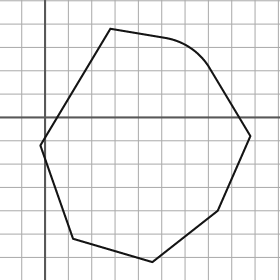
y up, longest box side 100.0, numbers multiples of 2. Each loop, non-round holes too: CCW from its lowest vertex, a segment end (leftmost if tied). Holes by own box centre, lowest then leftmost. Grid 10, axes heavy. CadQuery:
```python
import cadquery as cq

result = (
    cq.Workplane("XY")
    .moveTo(46.0, -62.0)
    .lineTo(74.0, -40.0)
    .lineTo(88.0, -8.0)
    .lineTo(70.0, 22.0)
    .threePointArc((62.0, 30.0), (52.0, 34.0))
    .lineTo(28.0, 38.0)
    .lineTo(-2.0, -12.0)
    .lineTo(12.0, -52.0)
    .close()
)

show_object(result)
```